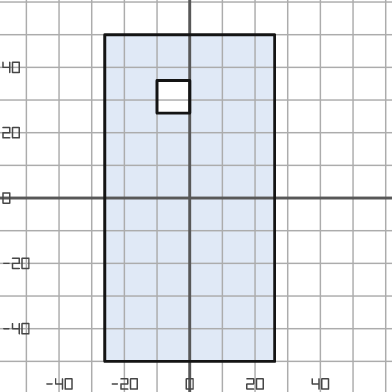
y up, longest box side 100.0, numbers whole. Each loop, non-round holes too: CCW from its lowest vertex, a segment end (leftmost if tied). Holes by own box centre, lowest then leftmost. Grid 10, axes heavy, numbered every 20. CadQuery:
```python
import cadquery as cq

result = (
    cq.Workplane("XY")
    .moveTo(-26.0, -50.0)
    .lineTo(26.0, -50.0)
    .lineTo(26.0, 50.0)
    .lineTo(-26.0, 50.0)
    .close()
    .moveTo(-10.0, 26.0)
    .lineTo(0.0, 26.0)
    .lineTo(0.0, 36.0)
    .lineTo(-10.0, 36.0)
    .close()
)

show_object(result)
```